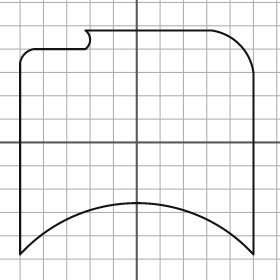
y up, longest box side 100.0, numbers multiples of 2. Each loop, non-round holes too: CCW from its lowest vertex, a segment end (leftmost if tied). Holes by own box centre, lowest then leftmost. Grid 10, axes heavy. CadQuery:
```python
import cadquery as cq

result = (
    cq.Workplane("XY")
    .moveTo(-50.0, -48.0)
    .threePointArc((0.0, -26.0), (50.0, -48.0))
    .lineTo(50.0, 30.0)
    .threePointArc((44.0, 42.0), (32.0, 48.0))
    .lineTo(-22.0, 48.0)
    .threePointArc((-20.0, 44.0), (-22.0, 40.0))
    .lineTo(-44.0, 40.0)
    .threePointArc((-48.0, 38.0), (-50.0, 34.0))
    .close()
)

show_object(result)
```